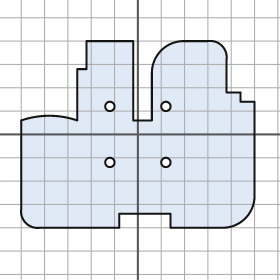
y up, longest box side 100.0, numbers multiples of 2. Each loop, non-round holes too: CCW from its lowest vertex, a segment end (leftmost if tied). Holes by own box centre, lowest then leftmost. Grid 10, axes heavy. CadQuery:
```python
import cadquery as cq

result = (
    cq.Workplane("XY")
    .moveTo(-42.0, -40.0)
    .lineTo(-8.0, -40.0)
    .lineTo(-8.0, -34.0)
    .lineTo(14.0, -34.0)
    .lineTo(14.0, -40.0)
    .lineTo(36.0, -40.0)
    .threePointArc((46.0, -36.0), (50.0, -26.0))
    .lineTo(50.0, 14.0)
    .lineTo(44.0, 14.0)
    .lineTo(44.0, 18.0)
    .lineTo(38.0, 18.0)
    .lineTo(38.0, 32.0)
    .threePointArc((36.0, 38.0), (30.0, 40.0))
    .lineTo(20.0, 40.0)
    .threePointArc((10.0, 36.0), (6.0, 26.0))
    .lineTo(6.0, 6.0)
    .lineTo(-2.0, 6.0)
    .lineTo(-2.0, 40.0)
    .lineTo(-22.0, 40.0)
    .lineTo(-22.0, 28.0)
    .lineTo(-26.0, 28.0)
    .lineTo(-26.0, 6.0)
    .threePointArc((-38.0, 8.0), (-50.0, 6.0))
    .lineTo(-50.0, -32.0)
    .threePointArc((-48.0, -38.0), (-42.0, -40.0))
    .close()
    .moveTo(-12.0, -12.0)
    .circle(2.0)
    .moveTo(12.0, -12.0)
    .circle(2.0)
    .moveTo(-12.0, 12.0)
    .circle(2.0)
    .moveTo(12.0, 12.0)
    .circle(2.0)
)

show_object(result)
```